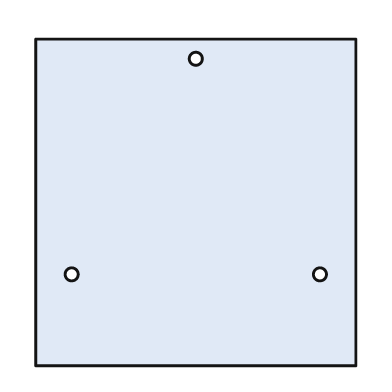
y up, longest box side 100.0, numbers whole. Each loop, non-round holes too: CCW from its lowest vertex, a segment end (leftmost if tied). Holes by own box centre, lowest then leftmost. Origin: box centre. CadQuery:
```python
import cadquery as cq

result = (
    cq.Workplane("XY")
    .moveTo(-49.0, -50.0)
    .lineTo(49.0, -50.0)
    .lineTo(49.0, 50.0)
    .lineTo(-49.0, 50.0)
    .close()
    .moveTo(-38.0, -22.0)
    .circle(2.0)
    .moveTo(38.0, -22.0)
    .circle(2.0)
    .moveTo(0.0, 44.0)
    .circle(2.0)
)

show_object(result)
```